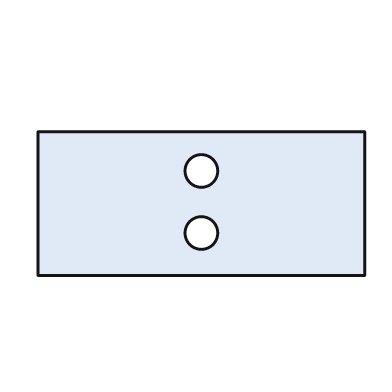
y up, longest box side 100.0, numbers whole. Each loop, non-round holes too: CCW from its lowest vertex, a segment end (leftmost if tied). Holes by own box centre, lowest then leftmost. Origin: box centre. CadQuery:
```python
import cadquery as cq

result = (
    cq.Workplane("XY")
    .moveTo(-50.0, -22.0)
    .lineTo(50.0, -22.0)
    .lineTo(50.0, 22.0)
    .lineTo(-50.0, 22.0)
    .close()
    .moveTo(0.0, -9.0)
    .circle(5.0)
    .moveTo(0.0, 10.0)
    .circle(5.0)
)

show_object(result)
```